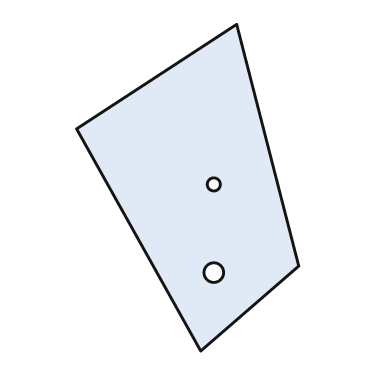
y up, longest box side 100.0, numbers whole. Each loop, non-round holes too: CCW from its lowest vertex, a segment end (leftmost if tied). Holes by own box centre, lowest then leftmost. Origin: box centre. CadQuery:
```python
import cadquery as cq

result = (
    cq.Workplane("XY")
    .moveTo(4.0, -50.0)
    .lineTo(34.0, -24.0)
    .lineTo(15.0, 50.0)
    .lineTo(-34.0, 18.0)
    .close()
    .moveTo(8.0, -26.0)
    .circle(3.0)
    .moveTo(8.0, 1.0)
    .circle(2.0)
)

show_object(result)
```